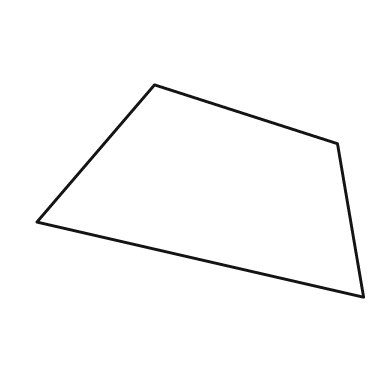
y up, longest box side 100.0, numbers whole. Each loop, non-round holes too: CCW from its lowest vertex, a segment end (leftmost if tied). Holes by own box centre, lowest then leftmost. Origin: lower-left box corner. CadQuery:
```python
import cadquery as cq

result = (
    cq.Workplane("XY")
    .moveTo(100.0, 0.0)
    .lineTo(92.0, 47.0)
    .lineTo(36.0, 65.0)
    .lineTo(0.0, 23.0)
    .close()
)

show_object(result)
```